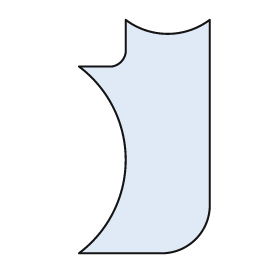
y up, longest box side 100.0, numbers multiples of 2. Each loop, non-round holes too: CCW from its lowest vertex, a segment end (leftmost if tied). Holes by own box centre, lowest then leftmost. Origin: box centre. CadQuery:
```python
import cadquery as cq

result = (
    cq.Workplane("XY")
    .moveTo(-28.0, -50.0)
    .lineTo(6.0, -50.0)
    .threePointArc((22.0, -44.0), (28.0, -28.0))
    .lineTo(28.0, 50.0)
    .threePointArc((10.0, 44.0), (-8.0, 50.0))
    .lineTo(-8.0, 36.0)
    .threePointArc((-10.0, 32.0), (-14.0, 30.0))
    .lineTo(-28.0, 30.0)
    .threePointArc((-8.0, -10.0), (-28.0, -50.0))
    .close()
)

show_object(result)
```